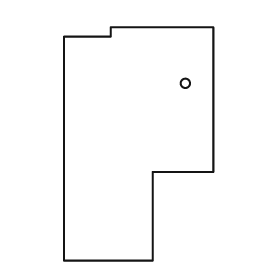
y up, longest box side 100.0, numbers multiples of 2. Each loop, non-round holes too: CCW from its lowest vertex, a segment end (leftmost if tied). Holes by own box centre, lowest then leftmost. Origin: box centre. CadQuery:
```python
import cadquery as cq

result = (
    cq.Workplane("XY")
    .moveTo(-32.0, -50.0)
    .lineTo(6.0, -50.0)
    .lineTo(6.0, -12.0)
    .lineTo(32.0, -12.0)
    .lineTo(32.0, 50.0)
    .lineTo(-12.0, 50.0)
    .lineTo(-12.0, 46.0)
    .lineTo(-32.0, 46.0)
    .close()
    .moveTo(20.0, 26.0)
    .circle(2.0)
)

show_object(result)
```